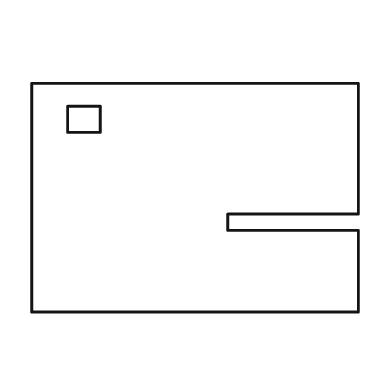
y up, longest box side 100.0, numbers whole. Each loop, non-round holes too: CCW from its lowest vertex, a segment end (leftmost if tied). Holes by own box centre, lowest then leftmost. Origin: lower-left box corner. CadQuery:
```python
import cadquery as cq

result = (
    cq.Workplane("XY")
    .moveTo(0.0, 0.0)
    .lineTo(100.0, 0.0)
    .lineTo(100.0, 25.0)
    .lineTo(60.0, 25.0)
    .lineTo(60.0, 30.0)
    .lineTo(100.0, 30.0)
    .lineTo(100.0, 70.0)
    .lineTo(0.0, 70.0)
    .close()
    .moveTo(11.0, 55.0)
    .lineTo(21.0, 55.0)
    .lineTo(21.0, 63.0)
    .lineTo(11.0, 63.0)
    .close()
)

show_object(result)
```